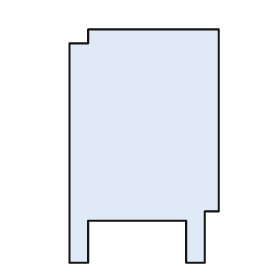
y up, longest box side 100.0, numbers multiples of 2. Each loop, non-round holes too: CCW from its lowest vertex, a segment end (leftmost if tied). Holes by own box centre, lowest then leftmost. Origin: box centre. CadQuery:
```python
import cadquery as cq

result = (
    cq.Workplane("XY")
    .moveTo(-32.0, -50.0)
    .lineTo(-24.0, -50.0)
    .lineTo(-24.0, -32.0)
    .lineTo(18.0, -32.0)
    .lineTo(18.0, -50.0)
    .lineTo(26.0, -50.0)
    .lineTo(26.0, -28.0)
    .lineTo(32.0, -28.0)
    .lineTo(32.0, 50.0)
    .lineTo(-24.0, 50.0)
    .lineTo(-24.0, 44.0)
    .lineTo(-32.0, 44.0)
    .close()
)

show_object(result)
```